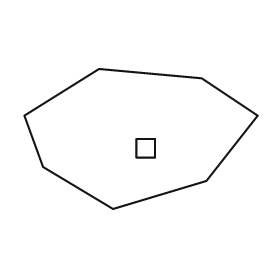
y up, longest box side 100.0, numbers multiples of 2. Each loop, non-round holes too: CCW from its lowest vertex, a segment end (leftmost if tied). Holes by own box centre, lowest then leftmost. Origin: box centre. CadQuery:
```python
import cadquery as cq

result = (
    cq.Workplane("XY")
    .moveTo(-12.0, -30.0)
    .lineTo(28.0, -18.0)
    .lineTo(50.0, 10.0)
    .lineTo(26.0, 26.0)
    .lineTo(-18.0, 30.0)
    .lineTo(-50.0, 10.0)
    .lineTo(-42.0, -12.0)
    .close()
    .moveTo(-2.0, -8.0)
    .lineTo(6.0, -8.0)
    .lineTo(6.0, 0.0)
    .lineTo(-2.0, 0.0)
    .close()
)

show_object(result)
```